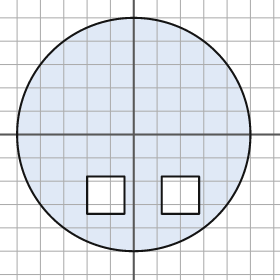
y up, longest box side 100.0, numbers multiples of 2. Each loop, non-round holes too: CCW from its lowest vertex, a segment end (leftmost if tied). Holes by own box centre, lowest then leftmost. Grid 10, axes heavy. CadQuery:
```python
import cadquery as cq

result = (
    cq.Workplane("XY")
    .moveTo(0.0, 0.0)
    .circle(50.0)
    .moveTo(-20.0, -34.0)
    .lineTo(-4.0, -34.0)
    .lineTo(-4.0, -18.0)
    .lineTo(-20.0, -18.0)
    .close()
    .moveTo(12.0, -34.0)
    .lineTo(28.0, -34.0)
    .lineTo(28.0, -18.0)
    .lineTo(12.0, -18.0)
    .close()
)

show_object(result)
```